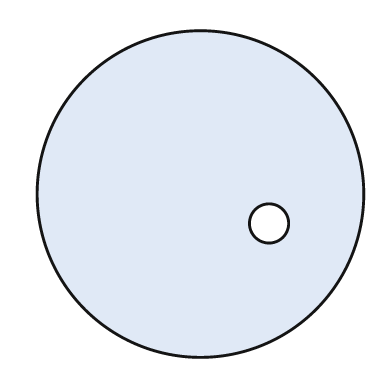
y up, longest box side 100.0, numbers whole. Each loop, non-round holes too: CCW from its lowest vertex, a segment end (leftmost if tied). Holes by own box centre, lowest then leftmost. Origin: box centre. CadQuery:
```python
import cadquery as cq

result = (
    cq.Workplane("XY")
    .moveTo(0.0, 0.0)
    .circle(50.0)
    .moveTo(21.0, -9.0)
    .circle(6.0)
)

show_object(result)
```